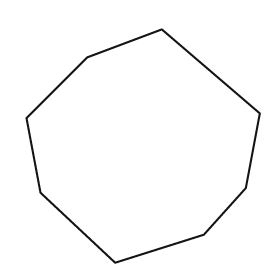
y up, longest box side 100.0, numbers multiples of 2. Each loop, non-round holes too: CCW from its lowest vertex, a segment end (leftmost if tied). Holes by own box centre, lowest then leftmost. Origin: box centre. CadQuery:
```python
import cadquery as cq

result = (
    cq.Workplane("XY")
    .moveTo(-12.0, -50.0)
    .lineTo(26.0, -38.0)
    .lineTo(44.0, -18.0)
    .lineTo(50.0, 14.0)
    .lineTo(8.0, 50.0)
    .lineTo(-24.0, 38.0)
    .lineTo(-50.0, 12.0)
    .lineTo(-44.0, -20.0)
    .close()
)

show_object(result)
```